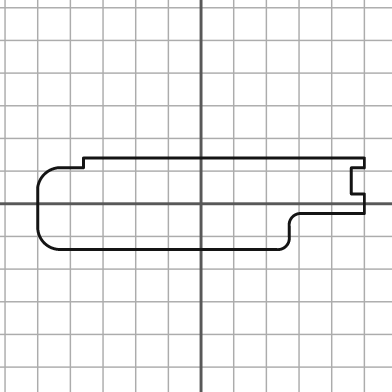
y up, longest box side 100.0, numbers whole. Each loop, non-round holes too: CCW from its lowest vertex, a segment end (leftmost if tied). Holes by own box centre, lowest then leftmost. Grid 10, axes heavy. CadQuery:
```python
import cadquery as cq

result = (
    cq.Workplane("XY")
    .moveTo(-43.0, -14.0)
    .lineTo(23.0, -14.0)
    .threePointArc((26.0, -13.0), (27.0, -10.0))
    .lineTo(27.0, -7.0)
    .threePointArc((28.0, -4.0), (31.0, -3.0))
    .lineTo(50.0, -3.0)
    .lineTo(50.0, 3.0)
    .lineTo(46.0, 3.0)
    .lineTo(46.0, 11.0)
    .lineTo(50.0, 11.0)
    .lineTo(50.0, 14.0)
    .lineTo(-36.0, 14.0)
    .lineTo(-36.0, 11.0)
    .lineTo(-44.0, 11.0)
    .threePointArc((-48.0, 9.0), (-50.0, 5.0))
    .lineTo(-50.0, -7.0)
    .threePointArc((-48.0, -12.0), (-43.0, -14.0))
    .close()
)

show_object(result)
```